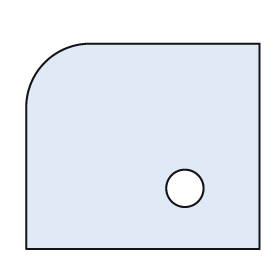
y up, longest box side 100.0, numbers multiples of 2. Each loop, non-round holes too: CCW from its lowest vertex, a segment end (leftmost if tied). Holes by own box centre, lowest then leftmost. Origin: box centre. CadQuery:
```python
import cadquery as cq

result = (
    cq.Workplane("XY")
    .moveTo(-50.0, -44.0)
    .lineTo(50.0, -44.0)
    .lineTo(50.0, 44.0)
    .lineTo(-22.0, 44.0)
    .threePointArc((-42.0, 36.0), (-50.0, 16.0))
    .close()
    .moveTo(18.0, -18.0)
    .circle(8.0)
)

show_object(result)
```